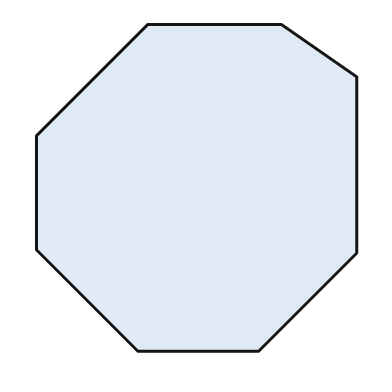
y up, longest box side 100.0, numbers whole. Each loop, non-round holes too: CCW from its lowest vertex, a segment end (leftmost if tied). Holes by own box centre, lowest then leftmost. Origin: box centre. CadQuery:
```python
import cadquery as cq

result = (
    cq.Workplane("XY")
    .moveTo(-18.0, -50.0)
    .lineTo(19.0, -50.0)
    .lineTo(49.0, -20.0)
    .lineTo(49.0, 34.0)
    .lineTo(26.0, 50.0)
    .lineTo(-15.0, 50.0)
    .lineTo(-49.0, 16.0)
    .lineTo(-49.0, -19.0)
    .close()
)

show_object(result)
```